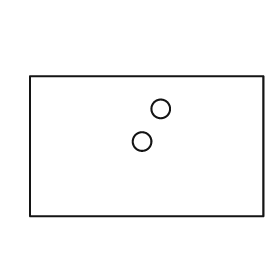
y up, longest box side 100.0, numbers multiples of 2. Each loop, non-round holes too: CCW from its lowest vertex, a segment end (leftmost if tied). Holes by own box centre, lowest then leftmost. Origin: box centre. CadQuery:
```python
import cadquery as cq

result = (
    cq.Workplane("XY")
    .moveTo(-50.0, -30.0)
    .lineTo(50.0, -30.0)
    .lineTo(50.0, 30.0)
    .lineTo(-50.0, 30.0)
    .close()
    .moveTo(-2.0, 2.0)
    .circle(4.0)
    .moveTo(6.0, 16.0)
    .circle(4.0)
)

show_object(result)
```